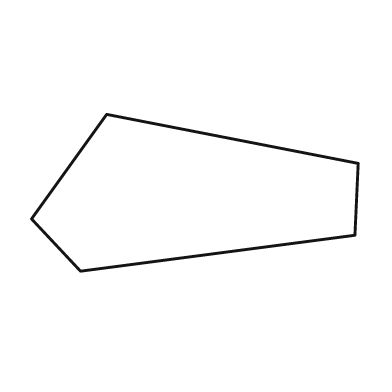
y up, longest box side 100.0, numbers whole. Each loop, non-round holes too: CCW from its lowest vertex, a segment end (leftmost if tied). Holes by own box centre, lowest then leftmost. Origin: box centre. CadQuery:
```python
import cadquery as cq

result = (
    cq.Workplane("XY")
    .moveTo(-35.0, -24.0)
    .lineTo(49.0, -13.0)
    .lineTo(50.0, 9.0)
    .lineTo(-27.0, 24.0)
    .lineTo(-50.0, -8.0)
    .close()
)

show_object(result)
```